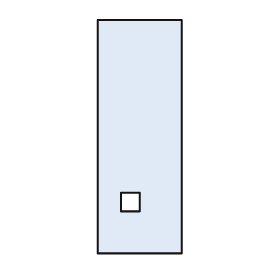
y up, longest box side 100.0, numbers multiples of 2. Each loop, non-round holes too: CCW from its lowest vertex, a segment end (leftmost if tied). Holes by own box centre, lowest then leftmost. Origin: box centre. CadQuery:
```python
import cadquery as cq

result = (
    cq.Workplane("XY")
    .moveTo(-18.0, -50.0)
    .lineTo(18.0, -50.0)
    .lineTo(18.0, 50.0)
    .lineTo(-18.0, 50.0)
    .close()
    .moveTo(-8.0, -32.0)
    .lineTo(0.0, -32.0)
    .lineTo(0.0, -24.0)
    .lineTo(-8.0, -24.0)
    .close()
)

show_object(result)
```